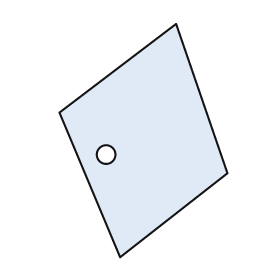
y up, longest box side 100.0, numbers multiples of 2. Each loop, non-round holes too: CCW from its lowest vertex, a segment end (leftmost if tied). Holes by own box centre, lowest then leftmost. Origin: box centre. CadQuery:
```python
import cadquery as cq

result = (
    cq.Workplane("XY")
    .moveTo(-10.0, -50.0)
    .lineTo(36.0, -14.0)
    .lineTo(14.0, 50.0)
    .lineTo(-36.0, 12.0)
    .close()
    .moveTo(-16.0, -6.0)
    .circle(4.0)
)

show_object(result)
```